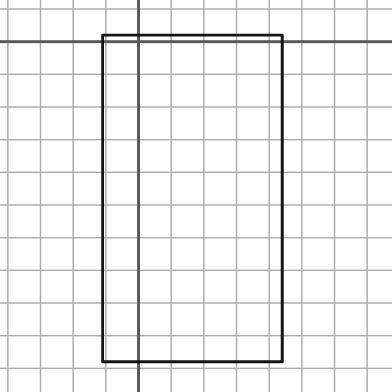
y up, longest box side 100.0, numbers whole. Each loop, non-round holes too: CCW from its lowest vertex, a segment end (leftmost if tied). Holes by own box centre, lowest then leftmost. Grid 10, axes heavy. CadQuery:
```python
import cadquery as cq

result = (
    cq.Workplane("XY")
    .moveTo(-11.0, -98.0)
    .lineTo(44.0, -98.0)
    .lineTo(44.0, 2.0)
    .lineTo(-11.0, 2.0)
    .close()
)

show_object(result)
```